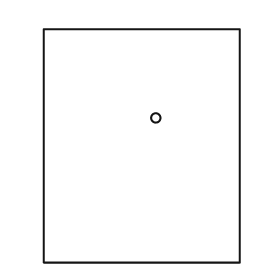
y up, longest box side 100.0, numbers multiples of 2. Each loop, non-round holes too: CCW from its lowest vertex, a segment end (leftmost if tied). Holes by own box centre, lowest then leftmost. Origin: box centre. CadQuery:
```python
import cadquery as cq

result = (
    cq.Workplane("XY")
    .moveTo(-42.0, -50.0)
    .lineTo(42.0, -50.0)
    .lineTo(42.0, 50.0)
    .lineTo(-42.0, 50.0)
    .close()
    .moveTo(6.0, 12.0)
    .circle(2.0)
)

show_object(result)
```